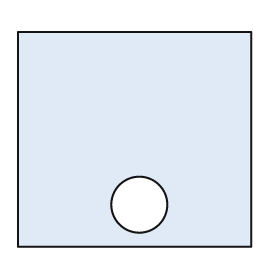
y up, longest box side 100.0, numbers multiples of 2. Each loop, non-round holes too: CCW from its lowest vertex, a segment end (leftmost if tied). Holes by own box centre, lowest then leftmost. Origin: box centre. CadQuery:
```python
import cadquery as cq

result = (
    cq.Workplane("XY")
    .moveTo(-50.0, -46.0)
    .lineTo(50.0, -46.0)
    .lineTo(50.0, 46.0)
    .lineTo(-50.0, 46.0)
    .close()
    .moveTo(2.0, -28.0)
    .circle(12.0)
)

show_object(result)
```